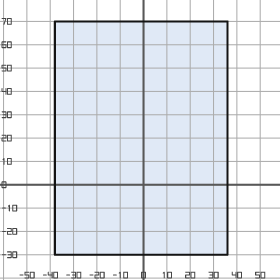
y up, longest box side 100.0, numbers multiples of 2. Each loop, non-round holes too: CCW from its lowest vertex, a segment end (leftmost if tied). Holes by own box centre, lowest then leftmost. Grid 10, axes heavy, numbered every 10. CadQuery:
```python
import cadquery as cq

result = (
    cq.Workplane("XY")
    .moveTo(-38.0, -30.0)
    .lineTo(36.0, -30.0)
    .lineTo(36.0, 70.0)
    .lineTo(-38.0, 70.0)
    .close()
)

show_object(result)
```